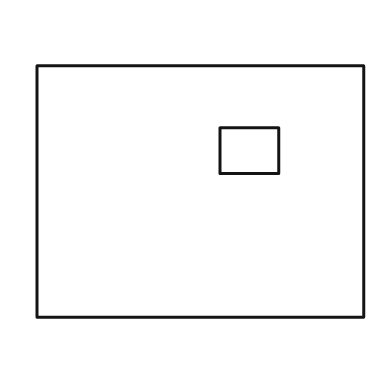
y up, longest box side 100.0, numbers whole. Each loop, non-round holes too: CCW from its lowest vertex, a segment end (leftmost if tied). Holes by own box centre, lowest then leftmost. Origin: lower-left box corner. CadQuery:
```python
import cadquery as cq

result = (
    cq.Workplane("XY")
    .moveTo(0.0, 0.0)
    .lineTo(100.0, 0.0)
    .lineTo(100.0, 77.0)
    .lineTo(0.0, 77.0)
    .close()
    .moveTo(56.0, 44.0)
    .lineTo(74.0, 44.0)
    .lineTo(74.0, 58.0)
    .lineTo(56.0, 58.0)
    .close()
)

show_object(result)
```